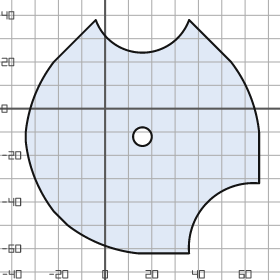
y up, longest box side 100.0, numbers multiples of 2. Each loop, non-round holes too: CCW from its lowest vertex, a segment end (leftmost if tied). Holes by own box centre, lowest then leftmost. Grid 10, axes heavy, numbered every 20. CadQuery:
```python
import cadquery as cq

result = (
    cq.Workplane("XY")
    .moveTo(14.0, -62.0)
    .lineTo(36.0, -62.0)
    .threePointArc((44.0, -40.0), (66.0, -32.0))
    .lineTo(66.0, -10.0)
    .threePointArc((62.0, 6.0), (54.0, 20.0))
    .lineTo(36.0, 38.0)
    .threePointArc((16.0, 24.0), (-4.0, 38.0))
    .lineTo(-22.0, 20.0)
    .threePointArc((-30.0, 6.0), (-34.0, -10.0))
    .lineTo(-34.0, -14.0)
    .threePointArc((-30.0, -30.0), (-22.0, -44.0))
    .lineTo(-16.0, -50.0)
    .threePointArc((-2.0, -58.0), (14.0, -62.0))
    .close()
    .moveTo(16.0, -12.0)
    .circle(4.0)
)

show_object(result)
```